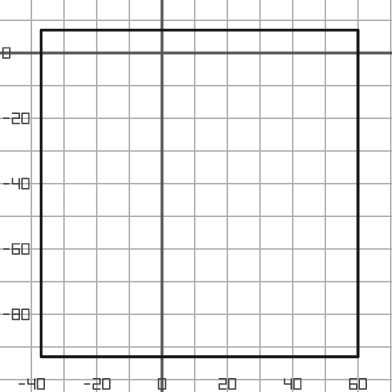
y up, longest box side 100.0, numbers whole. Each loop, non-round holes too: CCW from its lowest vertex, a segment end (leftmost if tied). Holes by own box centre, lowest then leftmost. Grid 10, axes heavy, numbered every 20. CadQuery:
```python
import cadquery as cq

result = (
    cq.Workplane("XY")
    .moveTo(-37.0, -93.0)
    .lineTo(60.0, -93.0)
    .lineTo(60.0, 7.0)
    .lineTo(-37.0, 7.0)
    .close()
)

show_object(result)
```